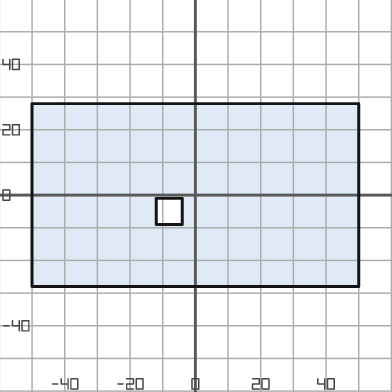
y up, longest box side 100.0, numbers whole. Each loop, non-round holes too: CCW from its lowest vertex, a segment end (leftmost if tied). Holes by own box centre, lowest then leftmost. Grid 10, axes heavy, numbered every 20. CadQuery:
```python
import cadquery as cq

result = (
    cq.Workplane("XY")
    .moveTo(-50.0, -28.0)
    .lineTo(50.0, -28.0)
    .lineTo(50.0, 28.0)
    .lineTo(-50.0, 28.0)
    .close()
    .moveTo(-12.0, -9.0)
    .lineTo(-4.0, -9.0)
    .lineTo(-4.0, -1.0)
    .lineTo(-12.0, -1.0)
    .close()
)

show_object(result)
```